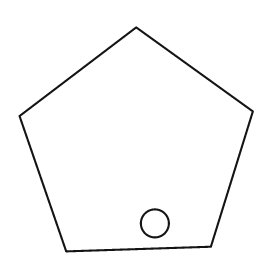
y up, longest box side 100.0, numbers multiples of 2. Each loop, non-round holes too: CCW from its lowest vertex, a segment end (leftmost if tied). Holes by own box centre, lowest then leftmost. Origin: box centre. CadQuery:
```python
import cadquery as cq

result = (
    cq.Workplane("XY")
    .moveTo(-30.0, -48.0)
    .lineTo(32.0, -46.0)
    .lineTo(50.0, 12.0)
    .lineTo(0.0, 48.0)
    .lineTo(-50.0, 10.0)
    .close()
    .moveTo(8.0, -36.0)
    .circle(6.0)
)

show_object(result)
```